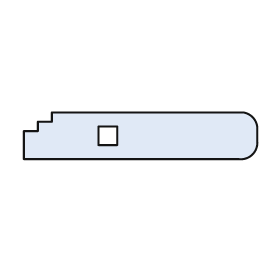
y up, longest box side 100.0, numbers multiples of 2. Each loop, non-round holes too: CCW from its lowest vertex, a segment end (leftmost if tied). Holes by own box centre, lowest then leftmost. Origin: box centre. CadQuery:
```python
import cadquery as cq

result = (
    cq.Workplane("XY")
    .moveTo(-50.0, -10.0)
    .lineTo(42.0, -10.0)
    .threePointArc((48.0, -8.0), (50.0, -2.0))
    .lineTo(50.0, 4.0)
    .threePointArc((48.0, 8.0), (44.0, 10.0))
    .lineTo(-38.0, 10.0)
    .lineTo(-38.0, 6.0)
    .lineTo(-44.0, 6.0)
    .lineTo(-44.0, 2.0)
    .lineTo(-50.0, 2.0)
    .close()
    .moveTo(-18.0, -4.0)
    .lineTo(-10.0, -4.0)
    .lineTo(-10.0, 4.0)
    .lineTo(-18.0, 4.0)
    .close()
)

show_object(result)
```